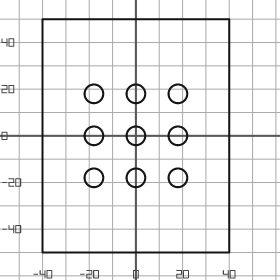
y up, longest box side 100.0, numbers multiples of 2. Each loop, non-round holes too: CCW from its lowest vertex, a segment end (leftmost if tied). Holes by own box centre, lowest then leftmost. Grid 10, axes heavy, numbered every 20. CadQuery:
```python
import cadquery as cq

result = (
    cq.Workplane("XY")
    .moveTo(-40.0, -50.0)
    .lineTo(40.0, -50.0)
    .lineTo(40.0, 50.0)
    .lineTo(-40.0, 50.0)
    .close()
    .moveTo(-18.0, -18.0)
    .circle(4.0)
    .moveTo(0.0, -18.0)
    .circle(4.0)
    .moveTo(18.0, -18.0)
    .circle(4.0)
    .moveTo(-18.0, 0.0)
    .circle(4.0)
    .moveTo(0.0, 0.0)
    .circle(4.0)
    .moveTo(18.0, 0.0)
    .circle(4.0)
    .moveTo(-18.0, 18.0)
    .circle(4.0)
    .moveTo(0.0, 18.0)
    .circle(4.0)
    .moveTo(18.0, 18.0)
    .circle(4.0)
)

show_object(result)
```